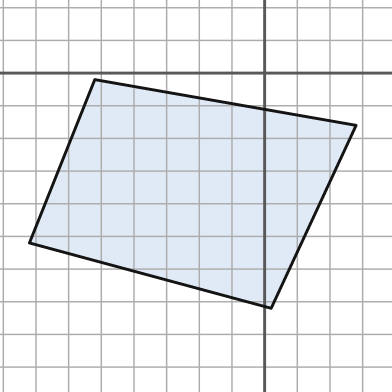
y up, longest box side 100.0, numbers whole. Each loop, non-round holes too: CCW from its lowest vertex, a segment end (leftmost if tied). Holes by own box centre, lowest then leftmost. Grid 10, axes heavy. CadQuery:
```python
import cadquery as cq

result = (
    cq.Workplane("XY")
    .moveTo(2.0, -72.0)
    .lineTo(28.0, -16.0)
    .lineTo(-52.0, -2.0)
    .lineTo(-72.0, -52.0)
    .close()
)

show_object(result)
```